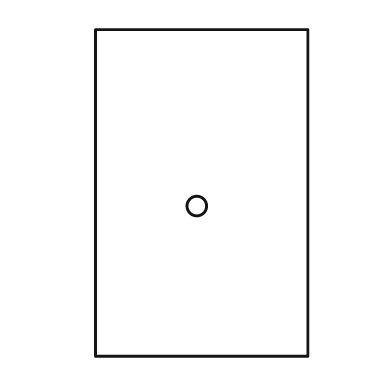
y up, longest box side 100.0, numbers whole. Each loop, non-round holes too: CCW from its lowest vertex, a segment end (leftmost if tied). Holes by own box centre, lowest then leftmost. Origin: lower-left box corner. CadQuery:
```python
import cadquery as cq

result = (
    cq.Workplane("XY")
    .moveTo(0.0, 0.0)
    .lineTo(65.0, 0.0)
    .lineTo(65.0, 100.0)
    .lineTo(0.0, 100.0)
    .close()
    .moveTo(31.0, 46.0)
    .circle(3.0)
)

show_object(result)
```